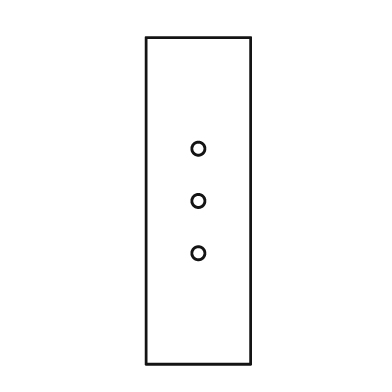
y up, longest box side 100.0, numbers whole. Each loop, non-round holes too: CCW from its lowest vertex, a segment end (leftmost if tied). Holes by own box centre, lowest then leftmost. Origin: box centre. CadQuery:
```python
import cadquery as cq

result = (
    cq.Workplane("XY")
    .moveTo(-16.0, -50.0)
    .lineTo(16.0, -50.0)
    .lineTo(16.0, 50.0)
    .lineTo(-16.0, 50.0)
    .close()
    .moveTo(0.0, -16.0)
    .circle(2.0)
    .moveTo(0.0, 0.0)
    .circle(2.0)
    .moveTo(0.0, 16.0)
    .circle(2.0)
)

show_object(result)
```